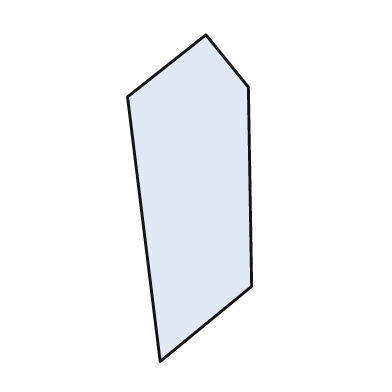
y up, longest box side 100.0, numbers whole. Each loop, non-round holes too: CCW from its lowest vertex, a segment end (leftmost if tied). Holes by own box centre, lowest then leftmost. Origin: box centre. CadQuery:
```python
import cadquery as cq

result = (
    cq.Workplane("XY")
    .moveTo(-9.0, -50.0)
    .lineTo(19.0, -27.0)
    .lineTo(18.0, 34.0)
    .lineTo(5.0, 50.0)
    .lineTo(-19.0, 31.0)
    .close()
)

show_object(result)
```